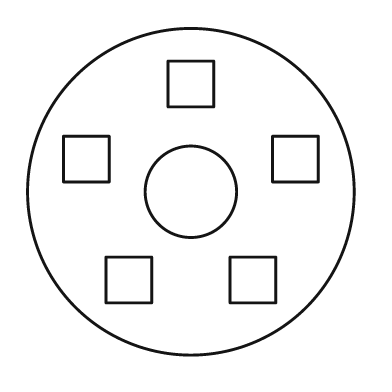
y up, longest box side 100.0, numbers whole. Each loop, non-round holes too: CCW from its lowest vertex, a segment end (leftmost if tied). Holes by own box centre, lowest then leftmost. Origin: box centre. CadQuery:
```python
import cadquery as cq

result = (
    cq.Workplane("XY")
    .moveTo(0.0, 0.0)
    .circle(50.0)
    .moveTo(-26.0, -34.0)
    .lineTo(-12.0, -34.0)
    .lineTo(-12.0, -20.0)
    .lineTo(-26.0, -20.0)
    .close()
    .moveTo(12.0, -34.0)
    .lineTo(26.0, -34.0)
    .lineTo(26.0, -20.0)
    .lineTo(12.0, -20.0)
    .close()
    .moveTo(0.0, 0.0)
    .circle(14.0)
    .moveTo(-39.0, 3.0)
    .lineTo(-25.0, 3.0)
    .lineTo(-25.0, 17.0)
    .lineTo(-39.0, 17.0)
    .close()
    .moveTo(25.0, 3.0)
    .lineTo(39.0, 3.0)
    .lineTo(39.0, 17.0)
    .lineTo(25.0, 17.0)
    .close()
    .moveTo(-7.0, 26.0)
    .lineTo(7.0, 26.0)
    .lineTo(7.0, 40.0)
    .lineTo(-7.0, 40.0)
    .close()
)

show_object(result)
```